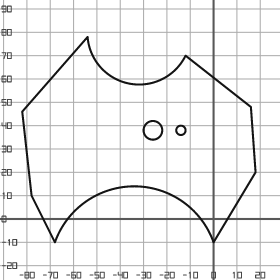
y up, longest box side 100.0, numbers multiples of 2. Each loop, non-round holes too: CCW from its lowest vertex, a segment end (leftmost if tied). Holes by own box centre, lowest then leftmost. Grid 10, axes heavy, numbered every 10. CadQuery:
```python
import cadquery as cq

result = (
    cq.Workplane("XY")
    .moveTo(-68.0, -10.0)
    .threePointArc((-34.0, 14.0), (0.0, -10.0))
    .lineTo(18.0, 20.0)
    .lineTo(16.0, 48.0)
    .lineTo(-12.0, 70.0)
    .threePointArc((-36.0, 58.0), (-54.0, 78.0))
    .lineTo(-82.0, 46.0)
    .lineTo(-78.0, 10.0)
    .close()
    .moveTo(-26.0, 38.0)
    .circle(4.0)
    .moveTo(-14.0, 38.0)
    .circle(2.0)
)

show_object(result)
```